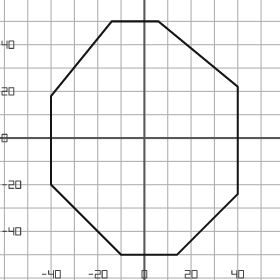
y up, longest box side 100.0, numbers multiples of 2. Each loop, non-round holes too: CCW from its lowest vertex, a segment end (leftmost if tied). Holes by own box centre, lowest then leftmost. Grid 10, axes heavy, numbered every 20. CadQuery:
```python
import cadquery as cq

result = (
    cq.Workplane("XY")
    .moveTo(-10.0, -50.0)
    .lineTo(14.0, -50.0)
    .lineTo(40.0, -24.0)
    .lineTo(40.0, 22.0)
    .lineTo(6.0, 50.0)
    .lineTo(-14.0, 50.0)
    .lineTo(-40.0, 18.0)
    .lineTo(-40.0, -20.0)
    .close()
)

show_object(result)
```